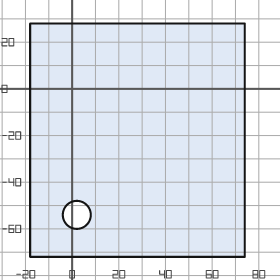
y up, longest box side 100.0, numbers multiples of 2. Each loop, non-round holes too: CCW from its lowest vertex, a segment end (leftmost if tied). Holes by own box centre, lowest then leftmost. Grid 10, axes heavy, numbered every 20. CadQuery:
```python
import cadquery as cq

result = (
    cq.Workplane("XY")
    .moveTo(-18.0, -72.0)
    .lineTo(74.0, -72.0)
    .lineTo(74.0, 28.0)
    .lineTo(-18.0, 28.0)
    .close()
    .moveTo(2.0, -54.0)
    .circle(6.0)
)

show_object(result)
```